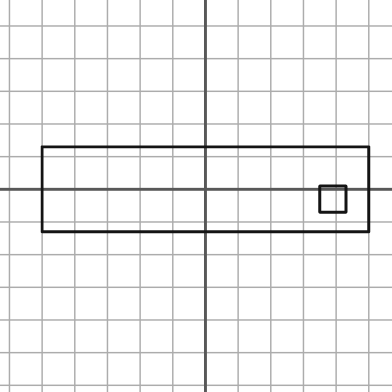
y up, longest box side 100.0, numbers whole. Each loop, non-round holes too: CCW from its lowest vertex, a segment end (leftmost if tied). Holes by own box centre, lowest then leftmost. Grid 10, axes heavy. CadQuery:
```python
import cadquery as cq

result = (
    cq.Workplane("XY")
    .moveTo(-50.0, -13.0)
    .lineTo(50.0, -13.0)
    .lineTo(50.0, 13.0)
    .lineTo(-50.0, 13.0)
    .close()
    .moveTo(35.0, -7.0)
    .lineTo(43.0, -7.0)
    .lineTo(43.0, 1.0)
    .lineTo(35.0, 1.0)
    .close()
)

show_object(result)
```